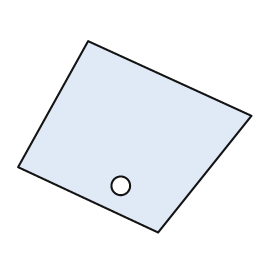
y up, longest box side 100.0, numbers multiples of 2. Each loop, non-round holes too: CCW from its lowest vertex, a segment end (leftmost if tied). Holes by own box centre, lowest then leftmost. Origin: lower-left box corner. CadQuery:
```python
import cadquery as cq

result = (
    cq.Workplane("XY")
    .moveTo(60.0, 0.0)
    .lineTo(100.0, 50.0)
    .lineTo(30.0, 82.0)
    .lineTo(0.0, 28.0)
    .close()
    .moveTo(44.0, 20.0)
    .circle(4.0)
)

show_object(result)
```